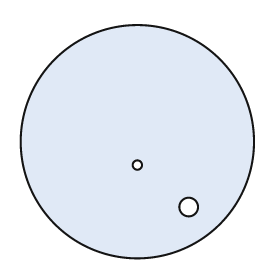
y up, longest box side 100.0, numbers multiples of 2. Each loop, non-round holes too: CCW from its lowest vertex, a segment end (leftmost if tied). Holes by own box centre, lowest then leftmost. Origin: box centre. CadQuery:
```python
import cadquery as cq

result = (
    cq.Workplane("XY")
    .moveTo(0.0, 0.0)
    .circle(50.0)
    .moveTo(22.0, -28.0)
    .circle(4.0)
    .moveTo(0.0, -10.0)
    .circle(2.0)
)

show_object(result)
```